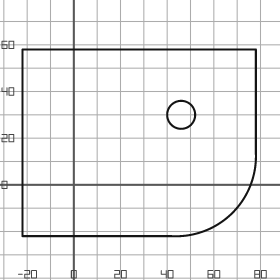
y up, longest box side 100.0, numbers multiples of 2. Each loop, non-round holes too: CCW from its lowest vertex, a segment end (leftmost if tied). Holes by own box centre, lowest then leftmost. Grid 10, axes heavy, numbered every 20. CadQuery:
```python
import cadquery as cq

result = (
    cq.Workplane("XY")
    .moveTo(-22.0, -22.0)
    .lineTo(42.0, -22.0)
    .threePointArc((68.0, -12.0), (78.0, 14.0))
    .lineTo(78.0, 58.0)
    .lineTo(-22.0, 58.0)
    .close()
    .moveTo(46.0, 30.0)
    .circle(6.0)
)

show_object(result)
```